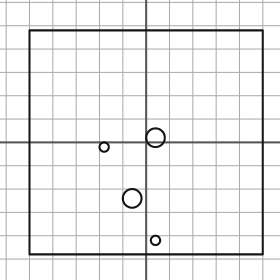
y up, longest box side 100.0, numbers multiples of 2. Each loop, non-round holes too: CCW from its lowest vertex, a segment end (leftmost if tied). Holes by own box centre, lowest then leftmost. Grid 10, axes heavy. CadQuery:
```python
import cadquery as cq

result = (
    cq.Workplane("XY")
    .moveTo(-50.0, -48.0)
    .lineTo(50.0, -48.0)
    .lineTo(50.0, 48.0)
    .lineTo(-50.0, 48.0)
    .close()
    .moveTo(4.0, -42.0)
    .circle(2.0)
    .moveTo(-6.0, -24.0)
    .circle(4.0)
    .moveTo(-18.0, -2.0)
    .circle(2.0)
    .moveTo(4.0, 2.0)
    .circle(4.0)
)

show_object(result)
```